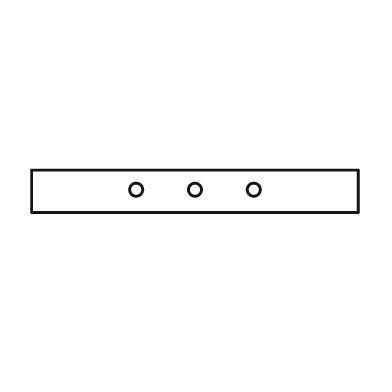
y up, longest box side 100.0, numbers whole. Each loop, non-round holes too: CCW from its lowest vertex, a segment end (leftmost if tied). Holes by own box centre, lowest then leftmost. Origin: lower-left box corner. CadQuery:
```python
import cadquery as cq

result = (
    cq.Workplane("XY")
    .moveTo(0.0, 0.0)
    .lineTo(100.0, 0.0)
    .lineTo(100.0, 13.0)
    .lineTo(0.0, 13.0)
    .close()
    .moveTo(32.0, 7.0)
    .circle(2.0)
    .moveTo(50.0, 7.0)
    .circle(2.0)
    .moveTo(68.0, 7.0)
    .circle(2.0)
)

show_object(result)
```